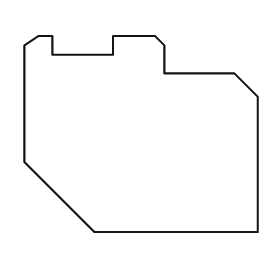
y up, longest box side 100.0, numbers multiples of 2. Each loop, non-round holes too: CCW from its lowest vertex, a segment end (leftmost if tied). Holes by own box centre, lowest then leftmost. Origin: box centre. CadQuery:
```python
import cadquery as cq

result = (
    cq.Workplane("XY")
    .moveTo(-20.0, -42.0)
    .lineTo(50.0, -42.0)
    .lineTo(50.0, 16.0)
    .lineTo(40.0, 26.0)
    .lineTo(10.0, 26.0)
    .lineTo(10.0, 38.0)
    .lineTo(6.0, 42.0)
    .lineTo(-12.0, 42.0)
    .lineTo(-12.0, 34.0)
    .lineTo(-38.0, 34.0)
    .lineTo(-38.0, 42.0)
    .lineTo(-44.0, 42.0)
    .lineTo(-50.0, 38.0)
    .lineTo(-50.0, -12.0)
    .close()
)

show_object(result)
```